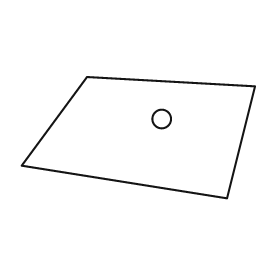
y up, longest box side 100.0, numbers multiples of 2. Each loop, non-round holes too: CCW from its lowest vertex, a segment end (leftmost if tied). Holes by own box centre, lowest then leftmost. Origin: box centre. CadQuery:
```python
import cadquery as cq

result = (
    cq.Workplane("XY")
    .moveTo(38.0, -26.0)
    .lineTo(50.0, 22.0)
    .lineTo(-22.0, 26.0)
    .lineTo(-50.0, -12.0)
    .close()
    .moveTo(10.0, 8.0)
    .circle(4.0)
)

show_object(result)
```